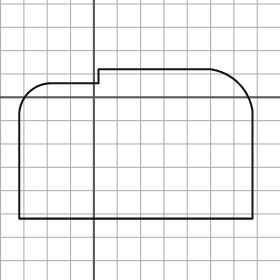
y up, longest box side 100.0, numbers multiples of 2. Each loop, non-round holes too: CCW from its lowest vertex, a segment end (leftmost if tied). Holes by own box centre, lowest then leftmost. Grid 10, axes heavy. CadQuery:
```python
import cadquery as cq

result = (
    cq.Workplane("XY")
    .moveTo(-32.0, -52.0)
    .lineTo(68.0, -52.0)
    .lineTo(68.0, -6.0)
    .threePointArc((62.0, 6.0), (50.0, 12.0))
    .lineTo(2.0, 12.0)
    .lineTo(2.0, 6.0)
    .lineTo(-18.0, 6.0)
    .threePointArc((-28.0, 2.0), (-32.0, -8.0))
    .close()
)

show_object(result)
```